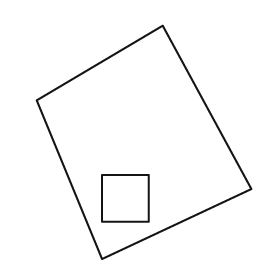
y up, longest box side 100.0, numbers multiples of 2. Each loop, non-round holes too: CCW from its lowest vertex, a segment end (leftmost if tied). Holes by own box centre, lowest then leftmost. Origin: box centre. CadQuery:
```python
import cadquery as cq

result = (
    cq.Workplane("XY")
    .moveTo(-18.0, -50.0)
    .lineTo(46.0, -20.0)
    .lineTo(8.0, 50.0)
    .lineTo(-46.0, 18.0)
    .close()
    .moveTo(-18.0, -34.0)
    .lineTo(2.0, -34.0)
    .lineTo(2.0, -14.0)
    .lineTo(-18.0, -14.0)
    .close()
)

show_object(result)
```